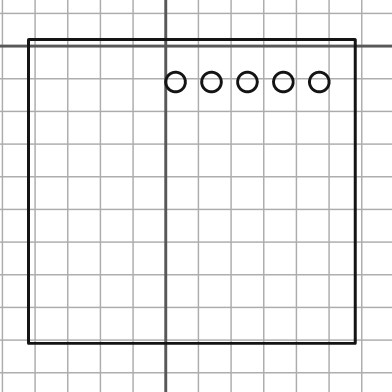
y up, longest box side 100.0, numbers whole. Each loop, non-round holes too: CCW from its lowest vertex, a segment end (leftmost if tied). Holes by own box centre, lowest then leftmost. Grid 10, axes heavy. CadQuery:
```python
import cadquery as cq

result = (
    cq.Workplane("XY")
    .moveTo(-42.0, -91.0)
    .lineTo(58.0, -91.0)
    .lineTo(58.0, 2.0)
    .lineTo(-42.0, 2.0)
    .close()
    .moveTo(3.0, -11.0)
    .circle(3.0)
    .moveTo(14.0, -11.0)
    .circle(3.0)
    .moveTo(25.0, -11.0)
    .circle(3.0)
    .moveTo(36.0, -11.0)
    .circle(3.0)
    .moveTo(47.0, -11.0)
    .circle(3.0)
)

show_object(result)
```